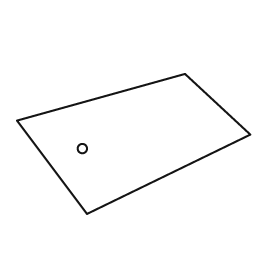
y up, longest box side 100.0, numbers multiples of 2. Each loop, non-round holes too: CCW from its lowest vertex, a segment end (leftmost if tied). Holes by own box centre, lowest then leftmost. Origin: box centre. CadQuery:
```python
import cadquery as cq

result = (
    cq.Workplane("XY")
    .moveTo(-20.0, -30.0)
    .lineTo(50.0, 4.0)
    .lineTo(22.0, 30.0)
    .lineTo(-50.0, 10.0)
    .close()
    .moveTo(-22.0, -2.0)
    .circle(2.0)
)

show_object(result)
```